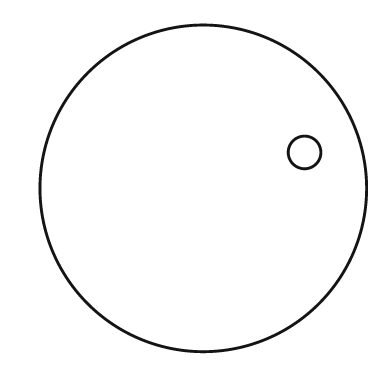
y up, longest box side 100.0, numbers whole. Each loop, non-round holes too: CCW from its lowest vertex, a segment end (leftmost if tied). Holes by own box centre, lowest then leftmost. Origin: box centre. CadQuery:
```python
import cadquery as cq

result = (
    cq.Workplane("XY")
    .moveTo(0.0, 0.0)
    .circle(50.0)
    .moveTo(31.0, 11.0)
    .circle(5.0)
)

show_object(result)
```